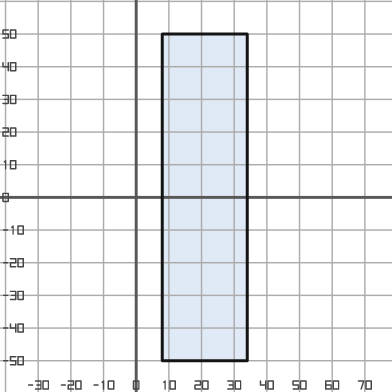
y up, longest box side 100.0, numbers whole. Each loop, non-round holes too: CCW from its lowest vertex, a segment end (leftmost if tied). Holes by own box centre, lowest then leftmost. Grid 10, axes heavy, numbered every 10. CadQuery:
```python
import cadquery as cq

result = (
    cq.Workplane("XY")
    .moveTo(8.0, -50.0)
    .lineTo(34.0, -50.0)
    .lineTo(34.0, 50.0)
    .lineTo(8.0, 50.0)
    .close()
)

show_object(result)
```